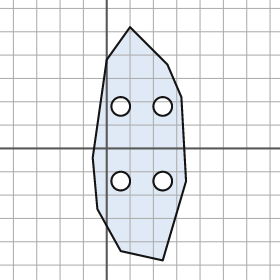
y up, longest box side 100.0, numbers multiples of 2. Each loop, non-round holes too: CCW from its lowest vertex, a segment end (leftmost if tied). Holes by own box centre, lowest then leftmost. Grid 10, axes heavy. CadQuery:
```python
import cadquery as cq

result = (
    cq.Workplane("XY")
    .moveTo(24.0, -48.0)
    .lineTo(34.0, -14.0)
    .lineTo(32.0, 22.0)
    .lineTo(26.0, 36.0)
    .lineTo(10.0, 52.0)
    .lineTo(0.0, 38.0)
    .lineTo(-6.0, -4.0)
    .lineTo(-4.0, -26.0)
    .lineTo(6.0, -44.0)
    .close()
    .moveTo(6.0, -14.0)
    .circle(4.0)
    .moveTo(24.0, -14.0)
    .circle(4.0)
    .moveTo(6.0, 18.0)
    .circle(4.0)
    .moveTo(24.0, 18.0)
    .circle(4.0)
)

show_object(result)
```